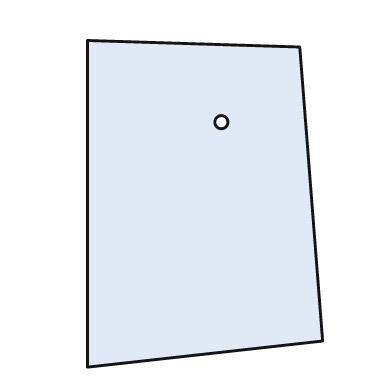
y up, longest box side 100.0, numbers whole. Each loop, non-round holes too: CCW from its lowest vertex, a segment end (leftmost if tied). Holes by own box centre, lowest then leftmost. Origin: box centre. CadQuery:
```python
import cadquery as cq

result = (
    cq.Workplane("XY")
    .moveTo(-36.0, -50.0)
    .lineTo(36.0, -42.0)
    .lineTo(29.0, 48.0)
    .lineTo(-36.0, 50.0)
    .close()
    .moveTo(5.0, 25.0)
    .circle(2.0)
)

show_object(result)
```